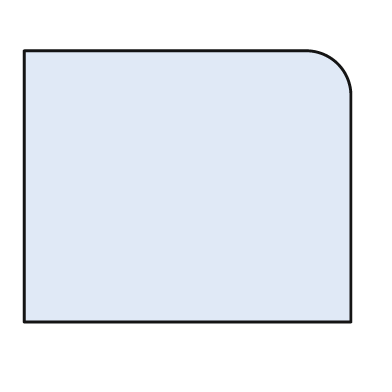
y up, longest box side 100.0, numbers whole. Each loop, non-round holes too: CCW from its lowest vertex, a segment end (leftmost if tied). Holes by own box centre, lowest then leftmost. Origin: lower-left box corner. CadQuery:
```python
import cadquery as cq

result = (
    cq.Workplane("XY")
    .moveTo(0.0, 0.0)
    .lineTo(100.0, 0.0)
    .lineTo(100.0, 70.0)
    .threePointArc((96.0, 79.0), (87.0, 83.0))
    .lineTo(0.0, 83.0)
    .close()
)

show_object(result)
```